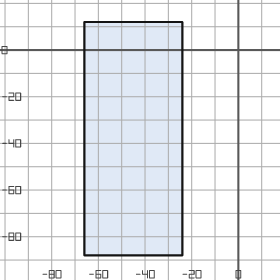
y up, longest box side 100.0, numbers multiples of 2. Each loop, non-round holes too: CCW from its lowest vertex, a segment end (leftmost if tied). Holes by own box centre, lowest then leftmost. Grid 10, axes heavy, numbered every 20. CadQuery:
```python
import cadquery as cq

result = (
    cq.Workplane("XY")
    .moveTo(-66.0, -88.0)
    .lineTo(-24.0, -88.0)
    .lineTo(-24.0, 12.0)
    .lineTo(-66.0, 12.0)
    .close()
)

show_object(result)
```